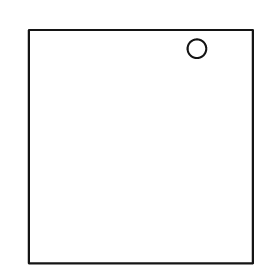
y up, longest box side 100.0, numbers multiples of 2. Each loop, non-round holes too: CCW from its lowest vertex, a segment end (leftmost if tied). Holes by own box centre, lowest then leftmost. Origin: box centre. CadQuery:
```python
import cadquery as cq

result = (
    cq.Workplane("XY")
    .moveTo(-48.0, -50.0)
    .lineTo(48.0, -50.0)
    .lineTo(48.0, 50.0)
    .lineTo(-48.0, 50.0)
    .close()
    .moveTo(24.0, 42.0)
    .circle(4.0)
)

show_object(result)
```